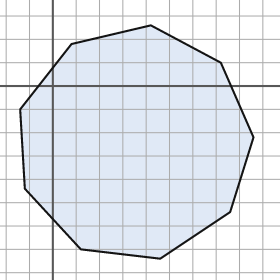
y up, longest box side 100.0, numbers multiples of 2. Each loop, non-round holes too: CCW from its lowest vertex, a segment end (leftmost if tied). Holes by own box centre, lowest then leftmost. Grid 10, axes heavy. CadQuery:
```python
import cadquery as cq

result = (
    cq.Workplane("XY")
    .moveTo(46.0, -74.0)
    .lineTo(76.0, -54.0)
    .lineTo(86.0, -22.0)
    .lineTo(72.0, 10.0)
    .lineTo(42.0, 26.0)
    .lineTo(8.0, 18.0)
    .lineTo(-14.0, -10.0)
    .lineTo(-12.0, -44.0)
    .lineTo(12.0, -70.0)
    .close()
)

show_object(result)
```